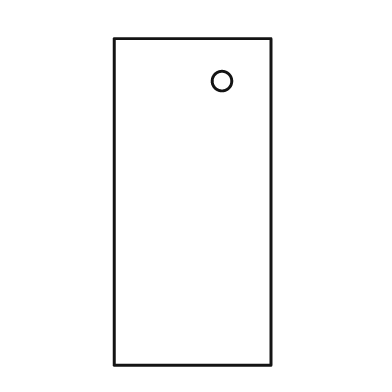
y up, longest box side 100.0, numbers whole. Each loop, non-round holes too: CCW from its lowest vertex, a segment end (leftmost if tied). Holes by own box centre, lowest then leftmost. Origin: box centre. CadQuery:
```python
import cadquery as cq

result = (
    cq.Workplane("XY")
    .moveTo(-24.0, -50.0)
    .lineTo(24.0, -50.0)
    .lineTo(24.0, 50.0)
    .lineTo(-24.0, 50.0)
    .close()
    .moveTo(9.0, 37.0)
    .circle(3.0)
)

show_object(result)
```